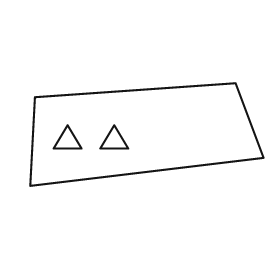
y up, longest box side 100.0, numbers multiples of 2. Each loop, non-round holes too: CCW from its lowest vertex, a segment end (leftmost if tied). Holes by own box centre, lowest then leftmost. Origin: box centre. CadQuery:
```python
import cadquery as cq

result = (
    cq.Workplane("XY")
    .moveTo(-50.0, -22.0)
    .lineTo(50.0, -10.0)
    .lineTo(38.0, 22.0)
    .lineTo(-48.0, 16.0)
    .close()
    .moveTo(-40.0, -6.0)
    .lineTo(-28.0, -6.0)
    .lineTo(-34.0, 4.0)
    .close()
    .moveTo(-20.0, -6.0)
    .lineTo(-8.0, -6.0)
    .lineTo(-14.0, 4.0)
    .close()
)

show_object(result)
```